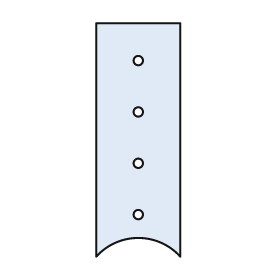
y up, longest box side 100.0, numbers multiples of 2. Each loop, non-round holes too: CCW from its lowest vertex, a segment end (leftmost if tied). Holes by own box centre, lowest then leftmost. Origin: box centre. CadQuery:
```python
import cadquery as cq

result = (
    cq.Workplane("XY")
    .moveTo(-18.0, -50.0)
    .threePointArc((0.0, -42.0), (18.0, -50.0))
    .lineTo(18.0, 50.0)
    .lineTo(-18.0, 50.0)
    .close()
    .moveTo(0.0, -32.0)
    .circle(2.0)
    .moveTo(0.0, -10.0)
    .circle(2.0)
    .moveTo(0.0, 12.0)
    .circle(2.0)
    .moveTo(0.0, 34.0)
    .circle(2.0)
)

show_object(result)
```